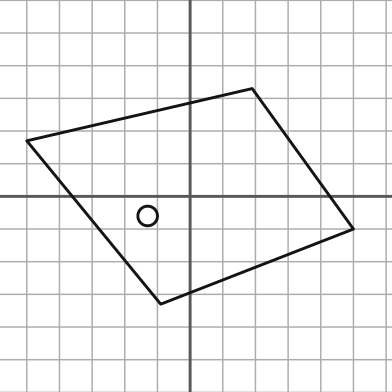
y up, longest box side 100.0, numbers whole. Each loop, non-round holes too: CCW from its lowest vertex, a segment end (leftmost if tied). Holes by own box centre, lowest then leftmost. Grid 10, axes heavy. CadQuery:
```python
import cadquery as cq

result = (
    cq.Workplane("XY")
    .moveTo(-9.0, -33.0)
    .lineTo(50.0, -10.0)
    .lineTo(19.0, 33.0)
    .lineTo(-50.0, 17.0)
    .close()
    .moveTo(-13.0, -6.0)
    .circle(3.0)
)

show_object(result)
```